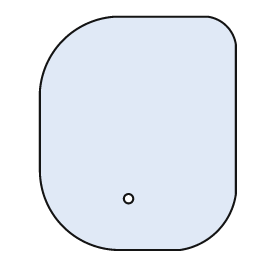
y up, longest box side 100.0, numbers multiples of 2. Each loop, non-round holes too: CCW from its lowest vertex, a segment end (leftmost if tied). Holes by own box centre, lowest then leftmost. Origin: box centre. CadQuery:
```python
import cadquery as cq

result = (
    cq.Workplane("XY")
    .moveTo(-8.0, -50.0)
    .lineTo(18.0, -50.0)
    .threePointArc((34.0, -42.0), (42.0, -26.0))
    .lineTo(42.0, 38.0)
    .threePointArc((38.0, 46.0), (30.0, 50.0))
    .lineTo(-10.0, 50.0)
    .threePointArc((-32.0, 40.0), (-42.0, 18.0))
    .lineTo(-42.0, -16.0)
    .threePointArc((-32.0, -40.0), (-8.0, -50.0))
    .close()
    .moveTo(-4.0, -28.0)
    .circle(2.0)
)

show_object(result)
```